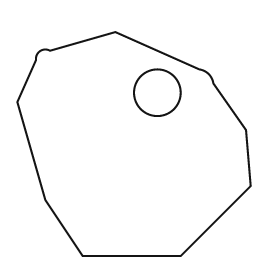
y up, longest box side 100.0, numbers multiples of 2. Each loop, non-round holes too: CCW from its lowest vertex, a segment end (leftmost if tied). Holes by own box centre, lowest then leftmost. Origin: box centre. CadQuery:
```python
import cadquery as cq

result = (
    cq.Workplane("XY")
    .moveTo(-22.0, -48.0)
    .lineTo(20.0, -48.0)
    .lineTo(50.0, -18.0)
    .lineTo(48.0, 6.0)
    .lineTo(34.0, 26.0)
    .threePointArc((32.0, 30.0), (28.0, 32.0))
    .lineTo(-8.0, 48.0)
    .lineTo(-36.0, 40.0)
    .threePointArc((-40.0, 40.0), (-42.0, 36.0))
    .lineTo(-50.0, 18.0)
    .lineTo(-38.0, -24.0)
    .close()
    .moveTo(10.0, 22.0)
    .circle(10.0)
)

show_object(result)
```